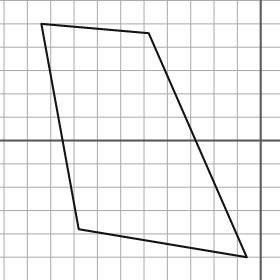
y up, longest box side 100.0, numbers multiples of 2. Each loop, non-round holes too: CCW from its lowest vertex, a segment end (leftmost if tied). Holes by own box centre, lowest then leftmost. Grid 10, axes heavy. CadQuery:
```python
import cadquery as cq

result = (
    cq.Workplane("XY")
    .moveTo(-6.0, -50.0)
    .lineTo(-48.0, 46.0)
    .lineTo(-94.0, 50.0)
    .lineTo(-78.0, -38.0)
    .close()
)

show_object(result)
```